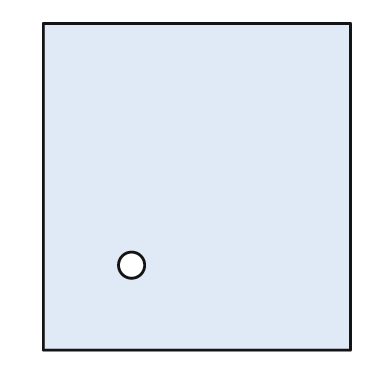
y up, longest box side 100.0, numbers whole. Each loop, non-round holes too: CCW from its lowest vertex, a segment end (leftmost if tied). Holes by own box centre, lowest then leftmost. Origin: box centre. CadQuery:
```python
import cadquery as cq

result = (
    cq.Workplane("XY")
    .moveTo(-47.0, -50.0)
    .lineTo(47.0, -50.0)
    .lineTo(47.0, 50.0)
    .lineTo(-47.0, 50.0)
    .close()
    .moveTo(-20.0, -24.0)
    .circle(4.0)
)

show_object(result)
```